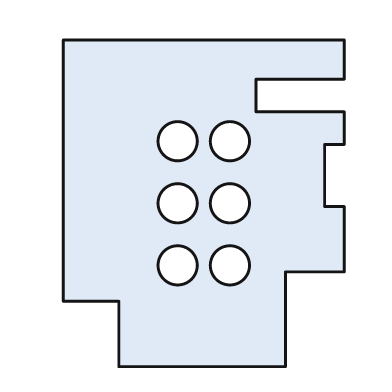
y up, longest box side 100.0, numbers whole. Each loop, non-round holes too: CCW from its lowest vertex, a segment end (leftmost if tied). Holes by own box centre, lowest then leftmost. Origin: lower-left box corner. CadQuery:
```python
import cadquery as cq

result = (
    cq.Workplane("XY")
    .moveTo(17.0, 0.0)
    .lineTo(68.0, 0.0)
    .lineTo(68.0, 29.0)
    .lineTo(86.0, 29.0)
    .lineTo(86.0, 49.0)
    .lineTo(80.0, 49.0)
    .lineTo(80.0, 68.0)
    .lineTo(86.0, 68.0)
    .lineTo(86.0, 78.0)
    .lineTo(59.0, 78.0)
    .lineTo(59.0, 88.0)
    .lineTo(86.0, 88.0)
    .lineTo(86.0, 100.0)
    .lineTo(0.0, 100.0)
    .lineTo(0.0, 20.0)
    .lineTo(17.0, 20.0)
    .close()
    .moveTo(35.0, 31.0)
    .circle(6.0)
    .moveTo(51.0, 31.0)
    .circle(6.0)
    .moveTo(35.0, 50.0)
    .circle(6.0)
    .moveTo(51.0, 50.0)
    .circle(6.0)
    .moveTo(35.0, 69.0)
    .circle(6.0)
    .moveTo(51.0, 69.0)
    .circle(6.0)
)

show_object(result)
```